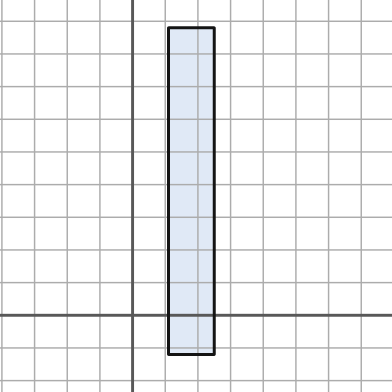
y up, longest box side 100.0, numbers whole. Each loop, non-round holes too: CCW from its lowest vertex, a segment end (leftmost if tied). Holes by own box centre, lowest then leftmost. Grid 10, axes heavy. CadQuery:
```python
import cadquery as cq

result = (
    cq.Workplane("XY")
    .moveTo(11.0, -12.0)
    .lineTo(25.0, -12.0)
    .lineTo(25.0, 88.0)
    .lineTo(11.0, 88.0)
    .close()
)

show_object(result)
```